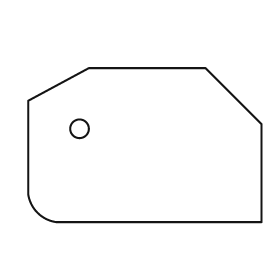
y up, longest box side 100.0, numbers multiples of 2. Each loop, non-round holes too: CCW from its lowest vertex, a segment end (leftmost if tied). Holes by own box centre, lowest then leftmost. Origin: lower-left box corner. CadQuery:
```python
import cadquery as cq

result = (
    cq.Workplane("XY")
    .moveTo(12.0, 0.0)
    .lineTo(100.0, 0.0)
    .lineTo(100.0, 42.0)
    .lineTo(76.0, 66.0)
    .lineTo(26.0, 66.0)
    .lineTo(0.0, 52.0)
    .lineTo(0.0, 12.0)
    .threePointArc((4.0, 4.0), (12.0, 0.0))
    .close()
    .moveTo(22.0, 40.0)
    .circle(4.0)
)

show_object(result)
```